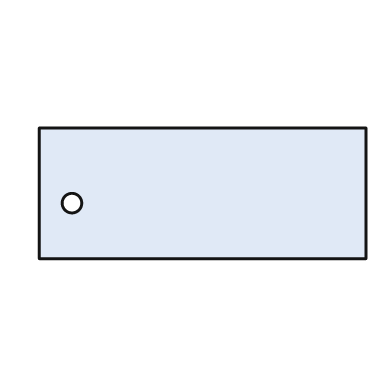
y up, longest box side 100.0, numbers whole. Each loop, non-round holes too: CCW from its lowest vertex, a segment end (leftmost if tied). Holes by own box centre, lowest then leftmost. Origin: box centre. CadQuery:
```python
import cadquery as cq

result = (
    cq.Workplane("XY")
    .moveTo(-50.0, -20.0)
    .lineTo(50.0, -20.0)
    .lineTo(50.0, 20.0)
    .lineTo(-50.0, 20.0)
    .close()
    .moveTo(-40.0, -3.0)
    .circle(3.0)
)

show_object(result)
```